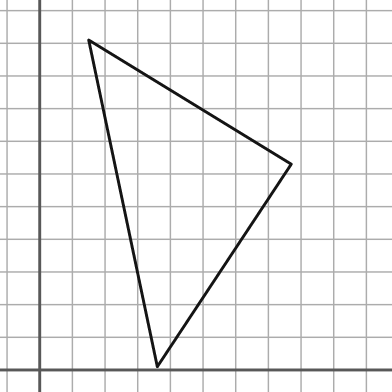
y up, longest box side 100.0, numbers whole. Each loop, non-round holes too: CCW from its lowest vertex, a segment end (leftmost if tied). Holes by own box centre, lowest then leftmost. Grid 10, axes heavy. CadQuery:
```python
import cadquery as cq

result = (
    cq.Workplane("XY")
    .moveTo(36.0, 1.0)
    .lineTo(77.0, 63.0)
    .lineTo(15.0, 101.0)
    .close()
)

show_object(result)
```